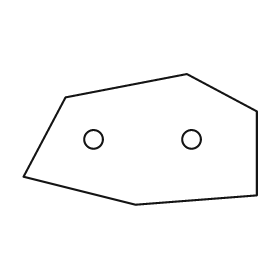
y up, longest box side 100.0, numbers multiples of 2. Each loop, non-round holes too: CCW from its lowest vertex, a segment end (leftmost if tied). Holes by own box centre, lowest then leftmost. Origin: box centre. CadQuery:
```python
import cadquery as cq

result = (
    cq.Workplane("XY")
    .moveTo(-2.0, -28.0)
    .lineTo(50.0, -24.0)
    .lineTo(50.0, 12.0)
    .lineTo(20.0, 28.0)
    .lineTo(-32.0, 18.0)
    .lineTo(-50.0, -16.0)
    .close()
    .moveTo(-20.0, 0.0)
    .circle(4.0)
    .moveTo(22.0, 0.0)
    .circle(4.0)
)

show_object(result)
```